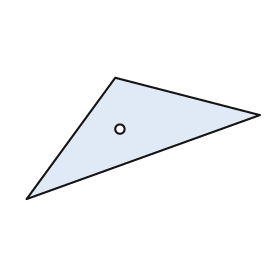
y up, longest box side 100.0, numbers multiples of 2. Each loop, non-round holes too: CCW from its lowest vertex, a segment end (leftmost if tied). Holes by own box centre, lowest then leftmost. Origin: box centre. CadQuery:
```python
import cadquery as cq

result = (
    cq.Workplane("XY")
    .moveTo(-50.0, -26.0)
    .lineTo(50.0, 10.0)
    .lineTo(-12.0, 26.0)
    .close()
    .moveTo(-10.0, 4.0)
    .circle(2.0)
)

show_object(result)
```